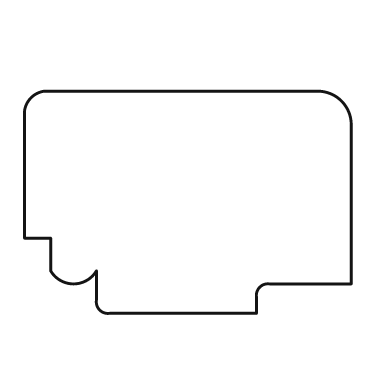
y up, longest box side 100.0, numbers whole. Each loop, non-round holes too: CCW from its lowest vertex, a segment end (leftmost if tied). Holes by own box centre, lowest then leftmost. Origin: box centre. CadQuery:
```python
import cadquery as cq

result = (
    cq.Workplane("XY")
    .moveTo(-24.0, -34.0)
    .lineTo(21.0, -34.0)
    .lineTo(21.0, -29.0)
    .threePointArc((22.0, -26.0), (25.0, -25.0))
    .lineTo(50.0, -25.0)
    .lineTo(50.0, 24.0)
    .threePointArc((47.0, 31.0), (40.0, 34.0))
    .lineTo(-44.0, 34.0)
    .threePointArc((-48.0, 32.0), (-50.0, 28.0))
    .lineTo(-50.0, -11.0)
    .lineTo(-42.0, -11.0)
    .lineTo(-42.0, -21.0)
    .threePointArc((-35.0, -25.0), (-28.0, -21.0))
    .lineTo(-28.0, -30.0)
    .threePointArc((-27.0, -33.0), (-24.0, -34.0))
    .close()
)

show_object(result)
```